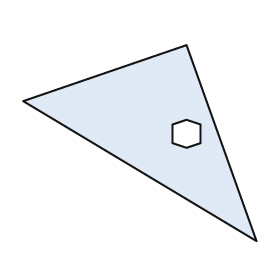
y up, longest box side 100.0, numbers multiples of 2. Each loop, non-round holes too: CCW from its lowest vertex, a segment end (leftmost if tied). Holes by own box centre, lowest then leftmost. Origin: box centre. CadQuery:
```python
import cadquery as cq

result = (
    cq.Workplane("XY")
    .moveTo(50.0, -42.0)
    .lineTo(20.0, 42.0)
    .lineTo(-50.0, 18.0)
    .close()
    .moveTo(20.0, -2.0)
    .lineTo(26.0, 0.0)
    .lineTo(26.0, 8.0)
    .lineTo(20.0, 10.0)
    .lineTo(14.0, 8.0)
    .lineTo(14.0, 0.0)
    .close()
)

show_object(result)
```